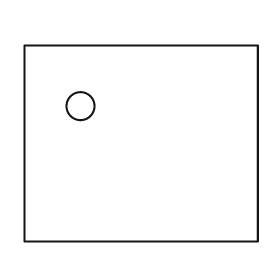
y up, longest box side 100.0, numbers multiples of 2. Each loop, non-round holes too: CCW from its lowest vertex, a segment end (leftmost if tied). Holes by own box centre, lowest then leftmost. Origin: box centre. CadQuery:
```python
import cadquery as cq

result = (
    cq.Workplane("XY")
    .moveTo(-50.0, -42.0)
    .lineTo(50.0, -42.0)
    .lineTo(50.0, 42.0)
    .lineTo(-50.0, 42.0)
    .close()
    .moveTo(-26.0, 16.0)
    .circle(6.0)
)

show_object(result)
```